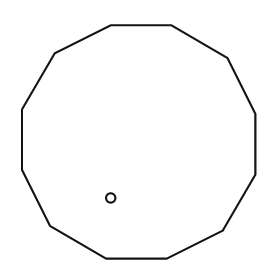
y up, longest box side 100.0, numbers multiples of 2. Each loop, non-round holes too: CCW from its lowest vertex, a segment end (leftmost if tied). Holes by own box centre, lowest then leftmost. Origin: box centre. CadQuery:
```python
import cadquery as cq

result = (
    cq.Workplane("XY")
    .moveTo(-14.0, -50.0)
    .lineTo(12.0, -50.0)
    .lineTo(36.0, -38.0)
    .lineTo(50.0, -14.0)
    .lineTo(50.0, 12.0)
    .lineTo(38.0, 36.0)
    .lineTo(14.0, 50.0)
    .lineTo(-12.0, 50.0)
    .lineTo(-36.0, 38.0)
    .lineTo(-50.0, 14.0)
    .lineTo(-50.0, -12.0)
    .lineTo(-38.0, -36.0)
    .close()
    .moveTo(-12.0, -24.0)
    .circle(2.0)
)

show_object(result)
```